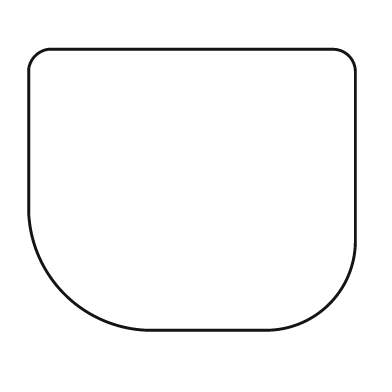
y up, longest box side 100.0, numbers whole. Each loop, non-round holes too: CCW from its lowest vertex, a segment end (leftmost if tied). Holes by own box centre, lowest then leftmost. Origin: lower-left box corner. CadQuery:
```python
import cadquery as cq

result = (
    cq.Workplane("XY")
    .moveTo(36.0, 0.0)
    .lineTo(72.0, 0.0)
    .threePointArc((92.0, 8.0), (100.0, 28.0))
    .lineTo(100.0, 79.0)
    .threePointArc((98.0, 84.0), (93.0, 86.0))
    .lineTo(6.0, 86.0)
    .threePointArc((2.0, 84.0), (0.0, 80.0))
    .lineTo(0.0, 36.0)
    .threePointArc((11.0, 11.0), (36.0, 0.0))
    .close()
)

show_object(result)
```